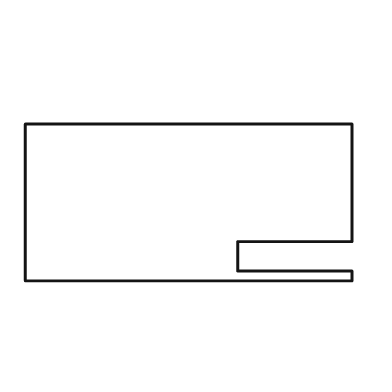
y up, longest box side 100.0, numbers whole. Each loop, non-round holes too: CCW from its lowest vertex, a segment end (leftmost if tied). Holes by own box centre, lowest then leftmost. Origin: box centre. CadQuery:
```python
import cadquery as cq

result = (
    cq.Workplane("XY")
    .moveTo(-50.0, -24.0)
    .lineTo(50.0, -24.0)
    .lineTo(50.0, -21.0)
    .lineTo(15.0, -21.0)
    .lineTo(15.0, -12.0)
    .lineTo(50.0, -12.0)
    .lineTo(50.0, 24.0)
    .lineTo(-50.0, 24.0)
    .close()
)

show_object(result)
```